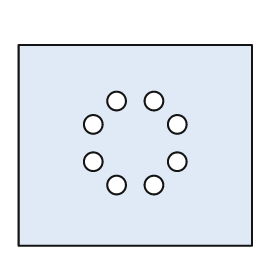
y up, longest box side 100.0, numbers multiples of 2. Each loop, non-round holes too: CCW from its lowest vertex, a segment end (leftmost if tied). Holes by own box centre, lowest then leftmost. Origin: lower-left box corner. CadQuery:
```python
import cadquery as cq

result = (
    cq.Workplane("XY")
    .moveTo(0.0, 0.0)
    .lineTo(100.0, 0.0)
    .lineTo(100.0, 86.0)
    .lineTo(0.0, 86.0)
    .close()
    .moveTo(42.0, 26.0)
    .circle(4.0)
    .moveTo(58.0, 26.0)
    .circle(4.0)
    .moveTo(32.0, 36.0)
    .circle(4.0)
    .moveTo(68.0, 36.0)
    .circle(4.0)
    .moveTo(32.0, 52.0)
    .circle(4.0)
    .moveTo(68.0, 52.0)
    .circle(4.0)
    .moveTo(42.0, 62.0)
    .circle(4.0)
    .moveTo(58.0, 62.0)
    .circle(4.0)
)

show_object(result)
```